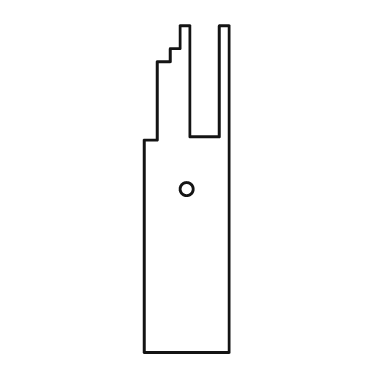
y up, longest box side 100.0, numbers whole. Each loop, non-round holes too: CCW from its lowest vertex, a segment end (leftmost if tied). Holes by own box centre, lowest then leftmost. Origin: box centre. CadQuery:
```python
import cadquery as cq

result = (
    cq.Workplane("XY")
    .moveTo(-13.0, -50.0)
    .lineTo(13.0, -50.0)
    .lineTo(13.0, 50.0)
    .lineTo(10.0, 50.0)
    .lineTo(10.0, 16.0)
    .lineTo(1.0, 16.0)
    .lineTo(1.0, 50.0)
    .lineTo(-2.0, 50.0)
    .lineTo(-2.0, 43.0)
    .lineTo(-5.0, 43.0)
    .lineTo(-5.0, 39.0)
    .lineTo(-9.0, 39.0)
    .lineTo(-9.0, 15.0)
    .lineTo(-13.0, 15.0)
    .close()
    .moveTo(0.0, 0.0)
    .circle(2.0)
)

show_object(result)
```